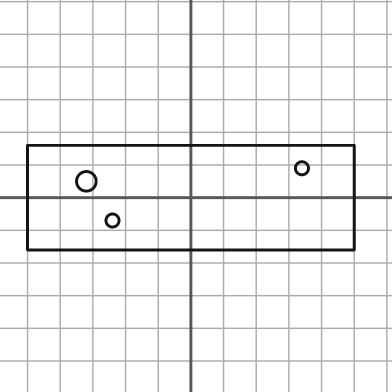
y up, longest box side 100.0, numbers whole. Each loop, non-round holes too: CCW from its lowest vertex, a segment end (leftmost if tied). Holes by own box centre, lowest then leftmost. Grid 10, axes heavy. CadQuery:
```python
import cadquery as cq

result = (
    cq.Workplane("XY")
    .moveTo(-50.0, -16.0)
    .lineTo(50.0, -16.0)
    .lineTo(50.0, 16.0)
    .lineTo(-50.0, 16.0)
    .close()
    .moveTo(-24.0, -7.0)
    .circle(2.0)
    .moveTo(-32.0, 5.0)
    .circle(3.0)
    .moveTo(34.0, 9.0)
    .circle(2.0)
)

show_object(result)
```